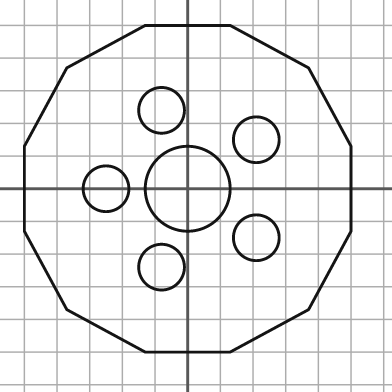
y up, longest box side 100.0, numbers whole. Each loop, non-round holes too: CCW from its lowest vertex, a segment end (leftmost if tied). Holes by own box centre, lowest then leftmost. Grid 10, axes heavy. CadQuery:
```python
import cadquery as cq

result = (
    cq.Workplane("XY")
    .moveTo(-13.0, -50.0)
    .lineTo(13.0, -50.0)
    .lineTo(37.0, -37.0)
    .lineTo(50.0, -13.0)
    .lineTo(50.0, 13.0)
    .lineTo(37.0, 37.0)
    .lineTo(13.0, 50.0)
    .lineTo(-13.0, 50.0)
    .lineTo(-37.0, 37.0)
    .lineTo(-50.0, 13.0)
    .lineTo(-50.0, -13.0)
    .lineTo(-37.0, -37.0)
    .close()
    .moveTo(-8.0, -24.0)
    .circle(7.0)
    .moveTo(21.0, -15.0)
    .circle(7.0)
    .moveTo(-25.0, 0.0)
    .circle(7.0)
    .moveTo(0.0, 0.0)
    .circle(13.0)
    .moveTo(21.0, 15.0)
    .circle(7.0)
    .moveTo(-8.0, 24.0)
    .circle(7.0)
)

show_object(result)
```